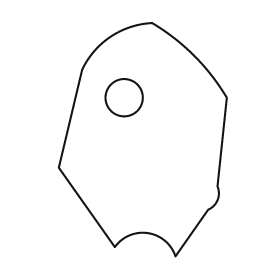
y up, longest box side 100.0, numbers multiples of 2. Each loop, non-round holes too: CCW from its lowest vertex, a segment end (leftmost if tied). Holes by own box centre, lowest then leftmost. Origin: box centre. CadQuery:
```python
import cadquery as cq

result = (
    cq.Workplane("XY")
    .moveTo(14.0, -50.0)
    .lineTo(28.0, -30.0)
    .threePointArc((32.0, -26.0), (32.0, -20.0))
    .lineTo(36.0, 18.0)
    .threePointArc((22.0, 36.0), (4.0, 50.0))
    .threePointArc((-14.0, 44.0), (-26.0, 30.0))
    .lineTo(-36.0, -12.0)
    .lineTo(-12.0, -46.0)
    .threePointArc((2.0, -40.0), (14.0, -50.0))
    .close()
    .moveTo(-8.0, 18.0)
    .circle(8.0)
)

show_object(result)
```